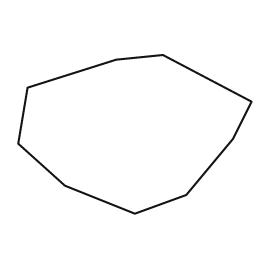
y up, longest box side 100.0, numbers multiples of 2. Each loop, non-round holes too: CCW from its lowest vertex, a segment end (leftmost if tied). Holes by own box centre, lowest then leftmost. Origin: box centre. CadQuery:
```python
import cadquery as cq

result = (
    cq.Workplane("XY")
    .moveTo(0.0, -34.0)
    .lineTo(22.0, -26.0)
    .lineTo(42.0, -2.0)
    .lineTo(50.0, 14.0)
    .lineTo(12.0, 34.0)
    .lineTo(-8.0, 32.0)
    .lineTo(-46.0, 20.0)
    .lineTo(-50.0, -4.0)
    .lineTo(-30.0, -22.0)
    .close()
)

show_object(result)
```